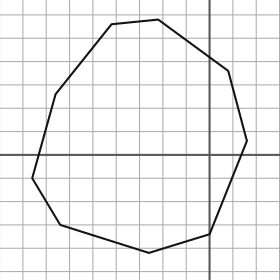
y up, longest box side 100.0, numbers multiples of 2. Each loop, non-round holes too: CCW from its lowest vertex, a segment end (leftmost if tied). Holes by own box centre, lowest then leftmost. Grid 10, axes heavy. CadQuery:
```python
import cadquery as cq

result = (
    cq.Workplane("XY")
    .moveTo(-26.0, -42.0)
    .lineTo(0.0, -34.0)
    .lineTo(16.0, 6.0)
    .lineTo(8.0, 36.0)
    .lineTo(-22.0, 58.0)
    .lineTo(-42.0, 56.0)
    .lineTo(-66.0, 26.0)
    .lineTo(-76.0, -10.0)
    .lineTo(-64.0, -30.0)
    .close()
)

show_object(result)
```